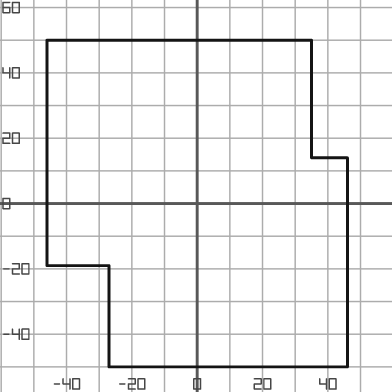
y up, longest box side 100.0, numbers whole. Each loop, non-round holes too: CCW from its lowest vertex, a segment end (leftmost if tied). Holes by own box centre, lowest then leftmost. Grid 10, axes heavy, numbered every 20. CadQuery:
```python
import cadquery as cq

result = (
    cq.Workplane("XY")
    .moveTo(-27.0, -50.0)
    .lineTo(46.0, -50.0)
    .lineTo(46.0, 14.0)
    .lineTo(35.0, 14.0)
    .lineTo(35.0, 50.0)
    .lineTo(-46.0, 50.0)
    .lineTo(-46.0, -19.0)
    .lineTo(-27.0, -19.0)
    .close()
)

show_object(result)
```